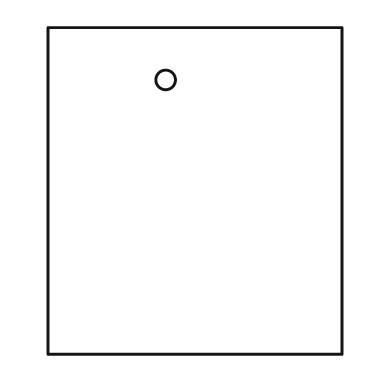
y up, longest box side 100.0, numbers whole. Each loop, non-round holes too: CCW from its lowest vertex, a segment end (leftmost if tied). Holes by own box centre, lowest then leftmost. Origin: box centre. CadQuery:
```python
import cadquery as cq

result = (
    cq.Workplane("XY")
    .moveTo(-45.0, -50.0)
    .lineTo(45.0, -50.0)
    .lineTo(45.0, 50.0)
    .lineTo(-45.0, 50.0)
    .close()
    .moveTo(-9.0, 34.0)
    .circle(3.0)
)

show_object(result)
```